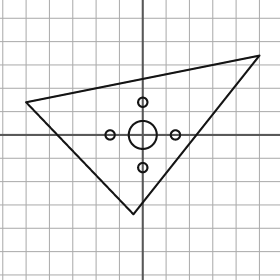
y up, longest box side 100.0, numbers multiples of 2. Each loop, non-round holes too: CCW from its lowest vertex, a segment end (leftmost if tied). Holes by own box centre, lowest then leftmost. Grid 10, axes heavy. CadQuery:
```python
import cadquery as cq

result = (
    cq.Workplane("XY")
    .moveTo(-4.0, -34.0)
    .lineTo(50.0, 34.0)
    .lineTo(-50.0, 14.0)
    .close()
    .moveTo(0.0, -14.0)
    .circle(2.0)
    .moveTo(-14.0, 0.0)
    .circle(2.0)
    .moveTo(0.0, 0.0)
    .circle(6.0)
    .moveTo(14.0, 0.0)
    .circle(2.0)
    .moveTo(0.0, 14.0)
    .circle(2.0)
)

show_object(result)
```